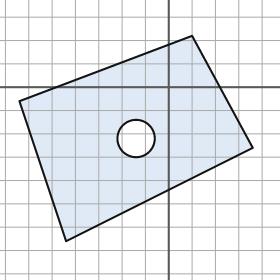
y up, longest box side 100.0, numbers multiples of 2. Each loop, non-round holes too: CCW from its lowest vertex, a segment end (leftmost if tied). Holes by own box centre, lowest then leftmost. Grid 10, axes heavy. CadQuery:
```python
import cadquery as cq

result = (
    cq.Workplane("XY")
    .moveTo(-44.0, -66.0)
    .lineTo(36.0, -26.0)
    .lineTo(10.0, 22.0)
    .lineTo(-64.0, -6.0)
    .close()
    .moveTo(-14.0, -22.0)
    .circle(8.0)
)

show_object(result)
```